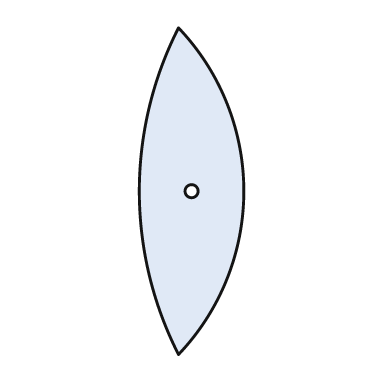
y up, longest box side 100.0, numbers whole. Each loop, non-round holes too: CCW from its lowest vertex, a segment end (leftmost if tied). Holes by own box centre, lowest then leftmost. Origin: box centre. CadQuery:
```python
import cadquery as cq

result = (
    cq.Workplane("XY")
    .moveTo(-4.0, -50.0)
    .threePointArc((16.0, 0.0), (-4.0, 50.0))
    .threePointArc((-16.0, 0.0), (-4.0, -50.0))
    .close()
    .moveTo(0.0, 0.0)
    .circle(2.0)
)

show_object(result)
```